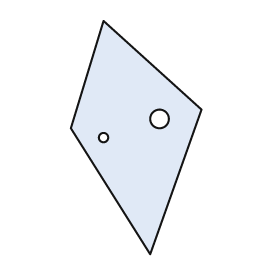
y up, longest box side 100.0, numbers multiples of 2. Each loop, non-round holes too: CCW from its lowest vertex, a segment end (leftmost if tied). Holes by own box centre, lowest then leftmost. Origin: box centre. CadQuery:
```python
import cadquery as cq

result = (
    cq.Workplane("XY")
    .moveTo(6.0, -50.0)
    .lineTo(28.0, 12.0)
    .lineTo(-14.0, 50.0)
    .lineTo(-28.0, 4.0)
    .close()
    .moveTo(-14.0, 0.0)
    .circle(2.0)
    .moveTo(10.0, 8.0)
    .circle(4.0)
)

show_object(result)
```